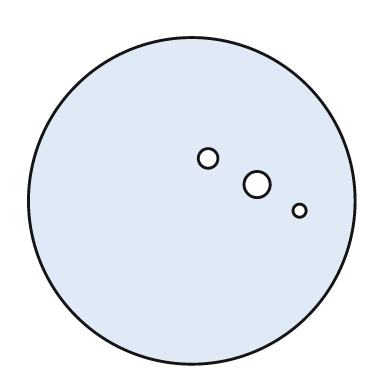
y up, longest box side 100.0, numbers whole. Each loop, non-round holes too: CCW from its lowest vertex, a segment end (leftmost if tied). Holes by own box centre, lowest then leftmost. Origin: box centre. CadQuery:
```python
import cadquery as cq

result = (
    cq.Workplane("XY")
    .moveTo(0.0, 0.0)
    .circle(50.0)
    .moveTo(33.0, -3.0)
    .circle(2.0)
    .moveTo(20.0, 5.0)
    .circle(4.0)
    .moveTo(5.0, 13.0)
    .circle(3.0)
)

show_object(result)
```